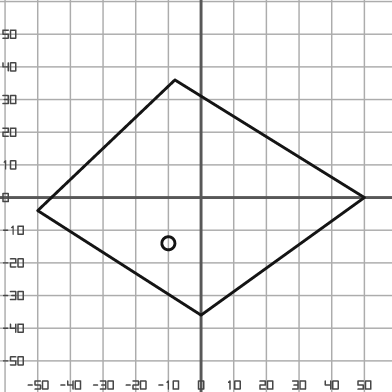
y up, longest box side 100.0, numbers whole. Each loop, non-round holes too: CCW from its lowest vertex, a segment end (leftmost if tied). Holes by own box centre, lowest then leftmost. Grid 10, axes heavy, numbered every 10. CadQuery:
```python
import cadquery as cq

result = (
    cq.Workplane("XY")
    .moveTo(0.0, -36.0)
    .lineTo(50.0, 0.0)
    .lineTo(-8.0, 36.0)
    .lineTo(-50.0, -4.0)
    .close()
    .moveTo(-10.0, -14.0)
    .circle(2.0)
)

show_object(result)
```